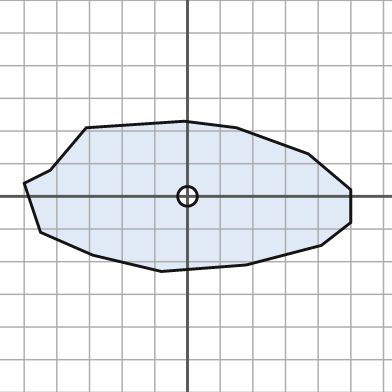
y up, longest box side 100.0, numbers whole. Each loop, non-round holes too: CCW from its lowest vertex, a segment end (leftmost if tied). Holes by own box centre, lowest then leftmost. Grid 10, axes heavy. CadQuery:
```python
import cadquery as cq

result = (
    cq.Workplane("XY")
    .moveTo(-8.0, -23.0)
    .lineTo(18.0, -21.0)
    .lineTo(41.0, -15.0)
    .lineTo(50.0, -8.0)
    .lineTo(50.0, 2.0)
    .lineTo(37.0, 13.0)
    .lineTo(15.0, 21.0)
    .lineTo(-1.0, 23.0)
    .lineTo(-31.0, 21.0)
    .lineTo(-42.0, 8.0)
    .lineTo(-50.0, 4.0)
    .lineTo(-45.0, -11.0)
    .lineTo(-29.0, -18.0)
    .close()
    .moveTo(0.0, 0.0)
    .circle(3.0)
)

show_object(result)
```